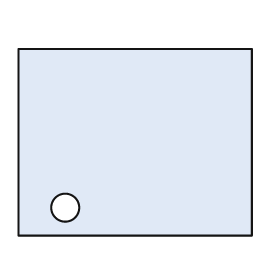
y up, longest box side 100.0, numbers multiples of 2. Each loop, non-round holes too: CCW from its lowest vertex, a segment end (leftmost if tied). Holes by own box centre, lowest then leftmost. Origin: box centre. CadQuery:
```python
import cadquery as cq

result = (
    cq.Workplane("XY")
    .moveTo(-50.0, -40.0)
    .lineTo(50.0, -40.0)
    .lineTo(50.0, 40.0)
    .lineTo(-50.0, 40.0)
    .close()
    .moveTo(-30.0, -28.0)
    .circle(6.0)
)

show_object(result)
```